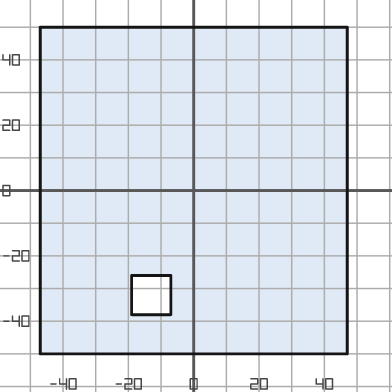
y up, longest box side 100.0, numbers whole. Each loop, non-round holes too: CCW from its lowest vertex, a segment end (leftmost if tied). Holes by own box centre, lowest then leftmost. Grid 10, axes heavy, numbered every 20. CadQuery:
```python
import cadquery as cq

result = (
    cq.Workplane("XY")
    .moveTo(-47.0, -50.0)
    .lineTo(47.0, -50.0)
    .lineTo(47.0, 50.0)
    .lineTo(-47.0, 50.0)
    .close()
    .moveTo(-19.0, -38.0)
    .lineTo(-7.0, -38.0)
    .lineTo(-7.0, -26.0)
    .lineTo(-19.0, -26.0)
    .close()
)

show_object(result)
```